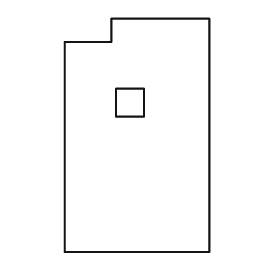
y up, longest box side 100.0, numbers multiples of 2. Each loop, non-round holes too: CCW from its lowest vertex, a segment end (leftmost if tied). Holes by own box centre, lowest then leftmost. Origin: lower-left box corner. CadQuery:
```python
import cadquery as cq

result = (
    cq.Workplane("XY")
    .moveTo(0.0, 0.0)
    .lineTo(62.0, 0.0)
    .lineTo(62.0, 100.0)
    .lineTo(20.0, 100.0)
    .lineTo(20.0, 90.0)
    .lineTo(0.0, 90.0)
    .close()
    .moveTo(22.0, 58.0)
    .lineTo(34.0, 58.0)
    .lineTo(34.0, 70.0)
    .lineTo(22.0, 70.0)
    .close()
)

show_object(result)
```